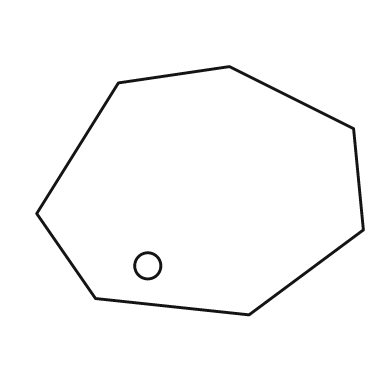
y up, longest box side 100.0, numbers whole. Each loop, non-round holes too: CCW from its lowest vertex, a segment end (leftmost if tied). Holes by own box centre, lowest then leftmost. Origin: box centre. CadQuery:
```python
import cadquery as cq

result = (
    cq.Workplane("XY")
    .moveTo(15.0, -38.0)
    .lineTo(50.0, -12.0)
    .lineTo(47.0, 19.0)
    .lineTo(9.0, 38.0)
    .lineTo(-25.0, 33.0)
    .lineTo(-50.0, -7.0)
    .lineTo(-32.0, -33.0)
    .close()
    .moveTo(-16.0, -23.0)
    .circle(4.0)
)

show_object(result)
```